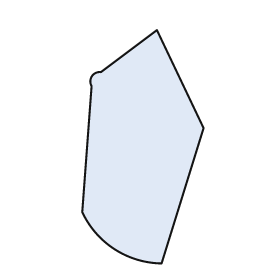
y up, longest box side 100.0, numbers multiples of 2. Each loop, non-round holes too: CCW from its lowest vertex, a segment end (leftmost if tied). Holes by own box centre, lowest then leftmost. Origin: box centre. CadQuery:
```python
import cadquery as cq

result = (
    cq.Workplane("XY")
    .moveTo(8.0, -50.0)
    .lineTo(26.0, 8.0)
    .lineTo(6.0, 50.0)
    .lineTo(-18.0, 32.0)
    .threePointArc((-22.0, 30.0), (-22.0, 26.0))
    .lineTo(-26.0, -28.0)
    .threePointArc((-12.0, -44.0), (8.0, -50.0))
    .close()
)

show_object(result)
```